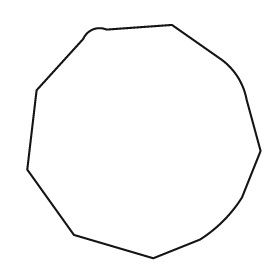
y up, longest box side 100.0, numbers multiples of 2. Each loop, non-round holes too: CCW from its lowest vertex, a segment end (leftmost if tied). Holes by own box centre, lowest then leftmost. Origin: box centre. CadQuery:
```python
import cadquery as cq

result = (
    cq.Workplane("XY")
    .moveTo(4.0, -50.0)
    .lineTo(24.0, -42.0)
    .threePointArc((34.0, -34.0), (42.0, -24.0))
    .lineTo(50.0, -4.0)
    .lineTo(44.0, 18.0)
    .threePointArc((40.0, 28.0), (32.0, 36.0))
    .lineTo(12.0, 50.0)
    .lineTo(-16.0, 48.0)
    .threePointArc((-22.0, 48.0), (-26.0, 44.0))
    .lineTo(-46.0, 22.0)
    .lineTo(-50.0, -12.0)
    .lineTo(-30.0, -40.0)
    .close()
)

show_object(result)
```